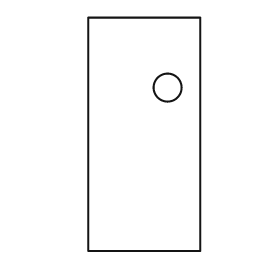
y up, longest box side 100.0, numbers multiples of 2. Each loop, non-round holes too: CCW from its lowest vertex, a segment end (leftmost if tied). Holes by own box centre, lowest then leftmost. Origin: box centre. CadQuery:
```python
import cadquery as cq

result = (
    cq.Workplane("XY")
    .moveTo(-24.0, -50.0)
    .lineTo(24.0, -50.0)
    .lineTo(24.0, 50.0)
    .lineTo(-24.0, 50.0)
    .close()
    .moveTo(10.0, 20.0)
    .circle(6.0)
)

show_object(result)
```